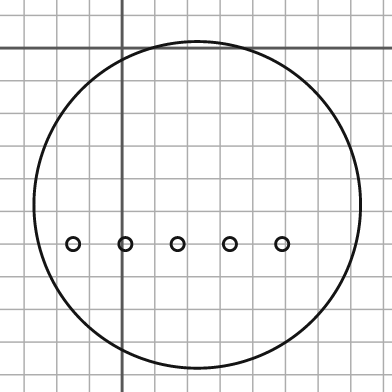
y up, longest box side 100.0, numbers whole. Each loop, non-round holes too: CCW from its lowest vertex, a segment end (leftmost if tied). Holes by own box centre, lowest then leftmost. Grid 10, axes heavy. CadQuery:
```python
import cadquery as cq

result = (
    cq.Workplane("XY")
    .moveTo(23.0, -48.0)
    .circle(50.0)
    .moveTo(-15.0, -60.0)
    .circle(2.0)
    .moveTo(1.0, -60.0)
    .circle(2.0)
    .moveTo(17.0, -60.0)
    .circle(2.0)
    .moveTo(33.0, -60.0)
    .circle(2.0)
    .moveTo(49.0, -60.0)
    .circle(2.0)
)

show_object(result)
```